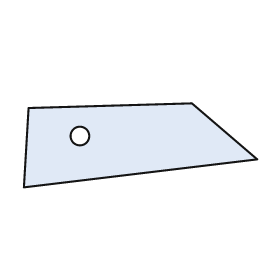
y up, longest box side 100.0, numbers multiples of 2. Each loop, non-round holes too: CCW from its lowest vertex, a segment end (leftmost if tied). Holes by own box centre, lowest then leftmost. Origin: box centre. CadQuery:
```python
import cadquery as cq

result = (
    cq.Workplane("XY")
    .moveTo(-50.0, -18.0)
    .lineTo(50.0, -6.0)
    .lineTo(22.0, 18.0)
    .lineTo(-48.0, 16.0)
    .close()
    .moveTo(-26.0, 4.0)
    .circle(4.0)
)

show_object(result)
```